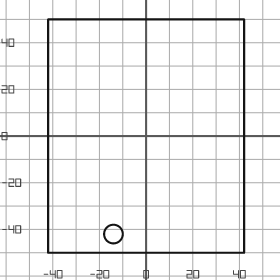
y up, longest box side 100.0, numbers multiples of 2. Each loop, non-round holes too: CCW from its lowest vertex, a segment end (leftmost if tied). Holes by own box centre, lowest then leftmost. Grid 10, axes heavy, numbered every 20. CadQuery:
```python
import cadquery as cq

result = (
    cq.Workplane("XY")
    .moveTo(-42.0, -50.0)
    .lineTo(42.0, -50.0)
    .lineTo(42.0, 50.0)
    .lineTo(-42.0, 50.0)
    .close()
    .moveTo(-14.0, -42.0)
    .circle(4.0)
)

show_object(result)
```